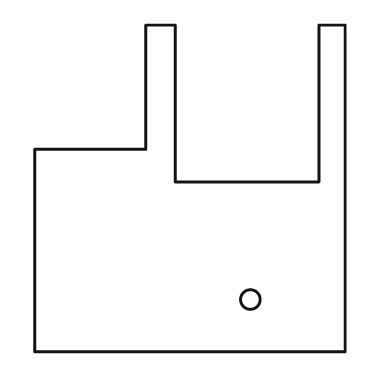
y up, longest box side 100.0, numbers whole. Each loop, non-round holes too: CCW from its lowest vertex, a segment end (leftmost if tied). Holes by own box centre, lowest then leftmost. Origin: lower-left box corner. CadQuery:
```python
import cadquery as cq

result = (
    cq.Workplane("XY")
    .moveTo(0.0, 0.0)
    .lineTo(95.0, 0.0)
    .lineTo(95.0, 100.0)
    .lineTo(87.0, 100.0)
    .lineTo(87.0, 52.0)
    .lineTo(43.0, 52.0)
    .lineTo(43.0, 100.0)
    .lineTo(34.0, 100.0)
    .lineTo(34.0, 62.0)
    .lineTo(0.0, 62.0)
    .close()
    .moveTo(66.0, 16.0)
    .circle(3.0)
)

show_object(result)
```